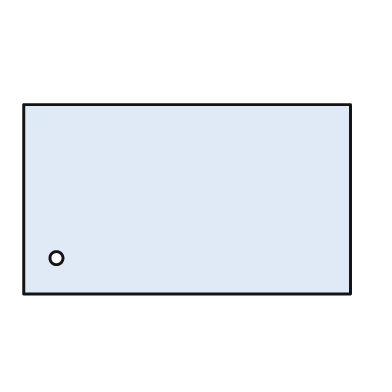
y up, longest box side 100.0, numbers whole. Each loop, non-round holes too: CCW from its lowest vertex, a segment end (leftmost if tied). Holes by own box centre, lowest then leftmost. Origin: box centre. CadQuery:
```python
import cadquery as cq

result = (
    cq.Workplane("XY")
    .moveTo(-50.0, -29.0)
    .lineTo(50.0, -29.0)
    .lineTo(50.0, 29.0)
    .lineTo(-50.0, 29.0)
    .close()
    .moveTo(-40.0, -18.0)
    .circle(2.0)
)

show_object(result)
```